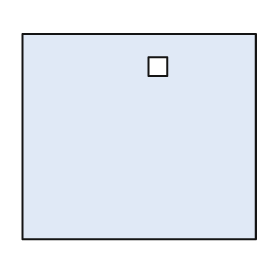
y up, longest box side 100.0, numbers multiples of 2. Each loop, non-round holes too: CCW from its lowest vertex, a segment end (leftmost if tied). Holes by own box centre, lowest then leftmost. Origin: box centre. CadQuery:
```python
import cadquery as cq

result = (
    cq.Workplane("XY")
    .moveTo(-50.0, -44.0)
    .lineTo(50.0, -44.0)
    .lineTo(50.0, 44.0)
    .lineTo(-50.0, 44.0)
    .close()
    .moveTo(4.0, 26.0)
    .lineTo(12.0, 26.0)
    .lineTo(12.0, 34.0)
    .lineTo(4.0, 34.0)
    .close()
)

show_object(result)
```